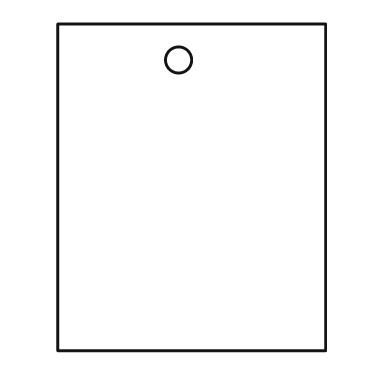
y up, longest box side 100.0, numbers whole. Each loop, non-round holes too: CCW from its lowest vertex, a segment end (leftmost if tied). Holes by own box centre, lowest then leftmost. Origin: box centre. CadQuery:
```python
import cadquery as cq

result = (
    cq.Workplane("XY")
    .moveTo(-41.0, -50.0)
    .lineTo(41.0, -50.0)
    .lineTo(41.0, 50.0)
    .lineTo(-41.0, 50.0)
    .close()
    .moveTo(-4.0, 39.0)
    .circle(4.0)
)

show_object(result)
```